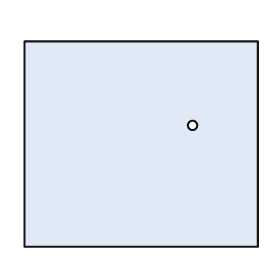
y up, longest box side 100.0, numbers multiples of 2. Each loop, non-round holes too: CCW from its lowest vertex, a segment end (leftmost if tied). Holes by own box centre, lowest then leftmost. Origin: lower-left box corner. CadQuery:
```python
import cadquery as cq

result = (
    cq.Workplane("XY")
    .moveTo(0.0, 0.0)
    .lineTo(100.0, 0.0)
    .lineTo(100.0, 88.0)
    .lineTo(0.0, 88.0)
    .close()
    .moveTo(72.0, 52.0)
    .circle(2.0)
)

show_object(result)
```